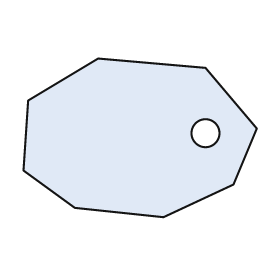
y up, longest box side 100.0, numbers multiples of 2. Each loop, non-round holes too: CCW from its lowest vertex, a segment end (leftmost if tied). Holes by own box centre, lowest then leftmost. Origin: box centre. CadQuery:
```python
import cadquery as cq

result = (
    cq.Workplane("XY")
    .moveTo(10.0, -34.0)
    .lineTo(40.0, -20.0)
    .lineTo(50.0, 4.0)
    .lineTo(28.0, 30.0)
    .lineTo(-18.0, 34.0)
    .lineTo(-48.0, 16.0)
    .lineTo(-50.0, -14.0)
    .lineTo(-28.0, -30.0)
    .close()
    .moveTo(28.0, 2.0)
    .circle(6.0)
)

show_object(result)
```